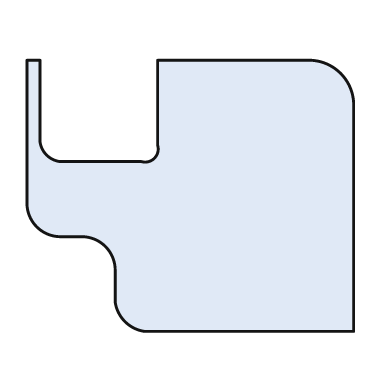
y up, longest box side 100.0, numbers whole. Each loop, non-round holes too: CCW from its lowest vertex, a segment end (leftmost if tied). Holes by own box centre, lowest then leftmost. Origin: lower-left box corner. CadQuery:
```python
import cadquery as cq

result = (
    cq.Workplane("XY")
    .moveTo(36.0, 0.0)
    .lineTo(100.0, 0.0)
    .lineTo(100.0, 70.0)
    .threePointArc((96.0, 79.0), (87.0, 83.0))
    .lineTo(40.0, 83.0)
    .lineTo(40.0, 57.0)
    .threePointArc((39.0, 53.0), (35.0, 52.0))
    .lineTo(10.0, 52.0)
    .threePointArc((6.0, 54.0), (4.0, 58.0))
    .lineTo(4.0, 83.0)
    .lineTo(0.0, 83.0)
    .lineTo(0.0, 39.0)
    .threePointArc((3.0, 32.0), (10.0, 29.0))
    .lineTo(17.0, 29.0)
    .threePointArc((24.0, 26.0), (27.0, 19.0))
    .lineTo(27.0, 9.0)
    .threePointArc((30.0, 3.0), (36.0, 0.0))
    .close()
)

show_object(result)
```